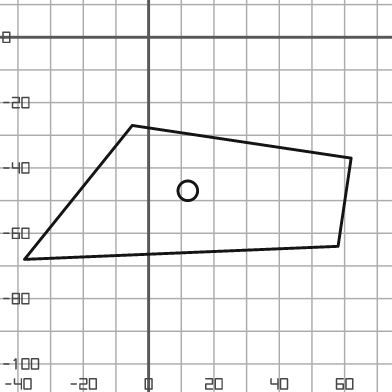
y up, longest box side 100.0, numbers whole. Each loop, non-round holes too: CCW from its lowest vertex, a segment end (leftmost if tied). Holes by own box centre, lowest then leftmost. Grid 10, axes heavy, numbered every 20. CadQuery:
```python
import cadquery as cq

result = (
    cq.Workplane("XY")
    .moveTo(-38.0, -68.0)
    .lineTo(58.0, -64.0)
    .lineTo(62.0, -37.0)
    .lineTo(-5.0, -27.0)
    .close()
    .moveTo(12.0, -47.0)
    .circle(3.0)
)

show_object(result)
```